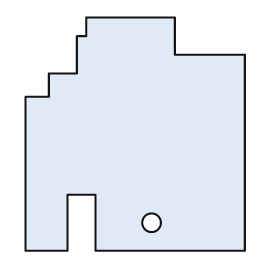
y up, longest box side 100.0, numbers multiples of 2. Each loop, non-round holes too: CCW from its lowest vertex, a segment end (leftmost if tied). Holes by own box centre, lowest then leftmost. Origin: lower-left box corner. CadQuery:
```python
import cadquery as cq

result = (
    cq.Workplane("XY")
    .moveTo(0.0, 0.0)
    .lineTo(18.0, 0.0)
    .lineTo(18.0, 24.0)
    .lineTo(30.0, 24.0)
    .lineTo(30.0, 0.0)
    .lineTo(94.0, 0.0)
    .lineTo(94.0, 84.0)
    .lineTo(64.0, 84.0)
    .lineTo(64.0, 100.0)
    .lineTo(26.0, 100.0)
    .lineTo(26.0, 92.0)
    .lineTo(22.0, 92.0)
    .lineTo(22.0, 76.0)
    .lineTo(10.0, 76.0)
    .lineTo(10.0, 66.0)
    .lineTo(0.0, 66.0)
    .close()
    .moveTo(54.0, 12.0)
    .circle(4.0)
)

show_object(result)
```